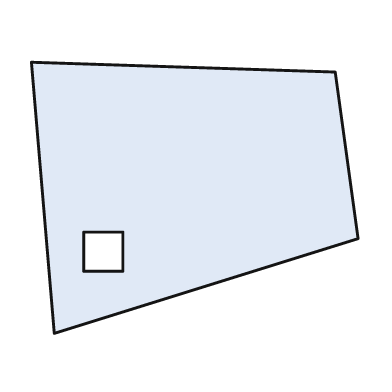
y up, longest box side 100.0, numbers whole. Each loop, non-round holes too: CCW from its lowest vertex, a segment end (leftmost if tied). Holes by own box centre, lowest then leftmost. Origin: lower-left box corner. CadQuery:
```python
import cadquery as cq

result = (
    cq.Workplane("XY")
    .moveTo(7.0, 0.0)
    .lineTo(100.0, 29.0)
    .lineTo(93.0, 80.0)
    .lineTo(0.0, 83.0)
    .close()
    .moveTo(16.0, 19.0)
    .lineTo(28.0, 19.0)
    .lineTo(28.0, 31.0)
    .lineTo(16.0, 31.0)
    .close()
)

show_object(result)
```